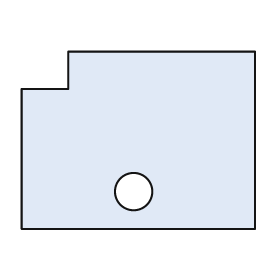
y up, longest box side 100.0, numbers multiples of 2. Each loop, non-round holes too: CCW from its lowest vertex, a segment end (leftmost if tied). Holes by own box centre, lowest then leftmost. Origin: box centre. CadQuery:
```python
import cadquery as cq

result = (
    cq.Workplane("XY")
    .moveTo(-50.0, -38.0)
    .lineTo(50.0, -38.0)
    .lineTo(50.0, 38.0)
    .lineTo(-30.0, 38.0)
    .lineTo(-30.0, 22.0)
    .lineTo(-50.0, 22.0)
    .close()
    .moveTo(-2.0, -22.0)
    .circle(8.0)
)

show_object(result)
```